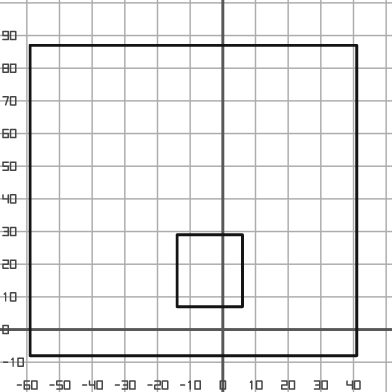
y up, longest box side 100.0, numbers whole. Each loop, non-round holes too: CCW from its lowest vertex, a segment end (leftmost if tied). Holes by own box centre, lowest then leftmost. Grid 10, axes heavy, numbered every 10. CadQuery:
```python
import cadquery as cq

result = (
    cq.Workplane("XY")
    .moveTo(-59.0, -8.0)
    .lineTo(41.0, -8.0)
    .lineTo(41.0, 87.0)
    .lineTo(-59.0, 87.0)
    .close()
    .moveTo(-14.0, 7.0)
    .lineTo(6.0, 7.0)
    .lineTo(6.0, 29.0)
    .lineTo(-14.0, 29.0)
    .close()
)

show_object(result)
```